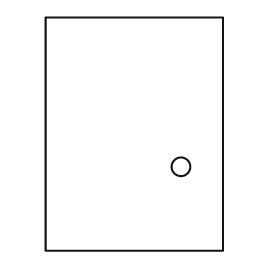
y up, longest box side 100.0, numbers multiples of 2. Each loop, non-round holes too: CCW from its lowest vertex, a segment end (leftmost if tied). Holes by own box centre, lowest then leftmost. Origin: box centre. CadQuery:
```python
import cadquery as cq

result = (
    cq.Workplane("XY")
    .moveTo(-38.0, -50.0)
    .lineTo(38.0, -50.0)
    .lineTo(38.0, 50.0)
    .lineTo(-38.0, 50.0)
    .close()
    .moveTo(20.0, -14.0)
    .circle(4.0)
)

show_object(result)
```